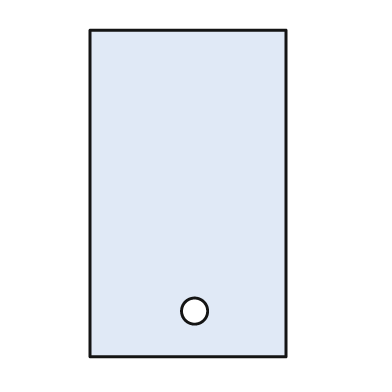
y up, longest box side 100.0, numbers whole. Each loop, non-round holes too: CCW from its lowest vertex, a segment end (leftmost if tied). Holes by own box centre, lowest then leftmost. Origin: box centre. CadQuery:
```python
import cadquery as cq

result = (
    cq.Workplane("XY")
    .moveTo(-30.0, -50.0)
    .lineTo(30.0, -50.0)
    .lineTo(30.0, 50.0)
    .lineTo(-30.0, 50.0)
    .close()
    .moveTo(2.0, -36.0)
    .circle(4.0)
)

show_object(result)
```